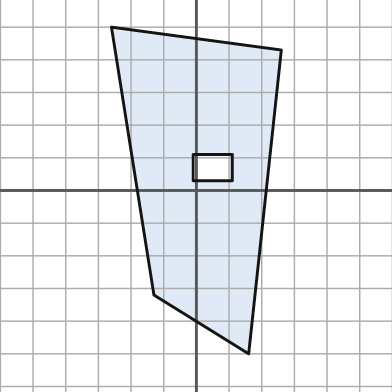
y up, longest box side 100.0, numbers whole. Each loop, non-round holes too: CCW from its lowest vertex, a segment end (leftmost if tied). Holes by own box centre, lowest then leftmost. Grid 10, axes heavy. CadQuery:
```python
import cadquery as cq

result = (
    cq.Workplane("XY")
    .moveTo(16.0, -50.0)
    .lineTo(26.0, 43.0)
    .lineTo(-26.0, 50.0)
    .lineTo(-13.0, -32.0)
    .close()
    .moveTo(-1.0, 3.0)
    .lineTo(11.0, 3.0)
    .lineTo(11.0, 11.0)
    .lineTo(-1.0, 11.0)
    .close()
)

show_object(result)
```